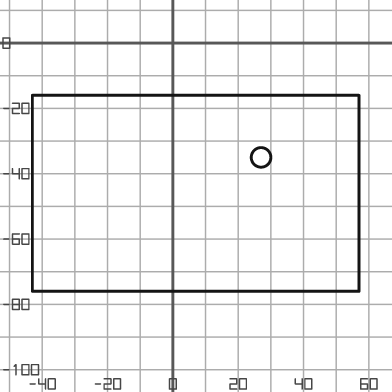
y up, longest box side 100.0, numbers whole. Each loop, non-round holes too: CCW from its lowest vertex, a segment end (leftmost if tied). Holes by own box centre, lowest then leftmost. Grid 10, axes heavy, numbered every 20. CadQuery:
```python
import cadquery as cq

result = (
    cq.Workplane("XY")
    .moveTo(-43.0, -76.0)
    .lineTo(57.0, -76.0)
    .lineTo(57.0, -16.0)
    .lineTo(-43.0, -16.0)
    .close()
    .moveTo(27.0, -35.0)
    .circle(3.0)
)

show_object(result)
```